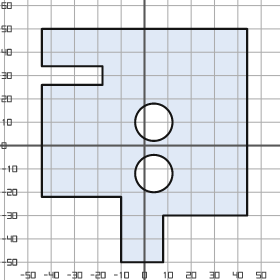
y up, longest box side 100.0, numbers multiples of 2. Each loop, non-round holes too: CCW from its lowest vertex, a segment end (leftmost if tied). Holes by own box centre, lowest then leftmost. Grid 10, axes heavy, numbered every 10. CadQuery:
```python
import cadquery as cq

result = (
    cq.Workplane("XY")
    .moveTo(-10.0, -50.0)
    .lineTo(8.0, -50.0)
    .lineTo(8.0, -30.0)
    .lineTo(44.0, -30.0)
    .lineTo(44.0, 50.0)
    .lineTo(-44.0, 50.0)
    .lineTo(-44.0, 34.0)
    .lineTo(-18.0, 34.0)
    .lineTo(-18.0, 26.0)
    .lineTo(-44.0, 26.0)
    .lineTo(-44.0, -22.0)
    .lineTo(-10.0, -22.0)
    .close()
    .moveTo(4.0, -12.0)
    .circle(8.0)
    .moveTo(4.0, 10.0)
    .circle(8.0)
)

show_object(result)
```